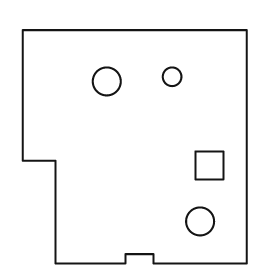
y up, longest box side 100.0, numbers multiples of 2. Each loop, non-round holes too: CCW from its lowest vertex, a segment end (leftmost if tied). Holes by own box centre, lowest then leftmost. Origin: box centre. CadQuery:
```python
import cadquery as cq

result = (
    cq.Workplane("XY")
    .moveTo(-34.0, -50.0)
    .lineTo(-4.0, -50.0)
    .lineTo(-4.0, -46.0)
    .lineTo(8.0, -46.0)
    .lineTo(8.0, -50.0)
    .lineTo(48.0, -50.0)
    .lineTo(48.0, 50.0)
    .lineTo(-48.0, 50.0)
    .lineTo(-48.0, -6.0)
    .lineTo(-34.0, -6.0)
    .close()
    .moveTo(28.0, -32.0)
    .circle(6.0)
    .moveTo(26.0, -14.0)
    .lineTo(38.0, -14.0)
    .lineTo(38.0, -2.0)
    .lineTo(26.0, -2.0)
    .close()
    .moveTo(-12.0, 28.0)
    .circle(6.0)
    .moveTo(16.0, 30.0)
    .circle(4.0)
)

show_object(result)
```